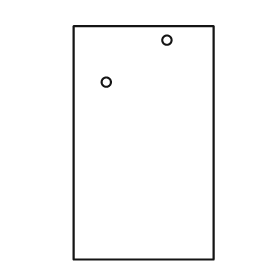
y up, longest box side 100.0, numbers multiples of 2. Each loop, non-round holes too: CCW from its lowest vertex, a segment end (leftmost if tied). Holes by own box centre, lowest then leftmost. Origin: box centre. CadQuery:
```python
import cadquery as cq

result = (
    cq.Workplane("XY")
    .moveTo(-30.0, -50.0)
    .lineTo(30.0, -50.0)
    .lineTo(30.0, 50.0)
    .lineTo(-30.0, 50.0)
    .close()
    .moveTo(-16.0, 26.0)
    .circle(2.0)
    .moveTo(10.0, 44.0)
    .circle(2.0)
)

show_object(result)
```